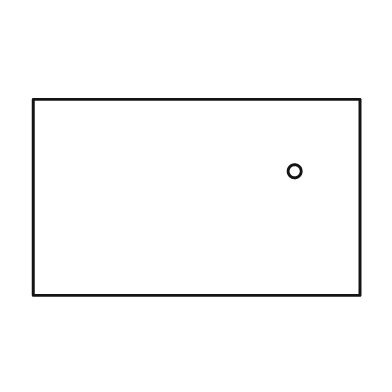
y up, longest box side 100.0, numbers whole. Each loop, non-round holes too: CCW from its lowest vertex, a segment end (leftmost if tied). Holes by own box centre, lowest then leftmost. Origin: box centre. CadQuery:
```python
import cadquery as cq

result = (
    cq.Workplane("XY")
    .moveTo(-50.0, -30.0)
    .lineTo(50.0, -30.0)
    .lineTo(50.0, 30.0)
    .lineTo(-50.0, 30.0)
    .close()
    .moveTo(30.0, 8.0)
    .circle(2.0)
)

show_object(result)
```